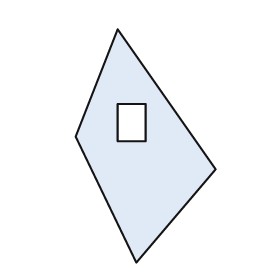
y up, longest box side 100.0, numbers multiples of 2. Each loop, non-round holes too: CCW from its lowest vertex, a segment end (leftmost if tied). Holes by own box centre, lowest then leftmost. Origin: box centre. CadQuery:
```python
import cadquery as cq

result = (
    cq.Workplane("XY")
    .moveTo(-4.0, -50.0)
    .lineTo(30.0, -10.0)
    .lineTo(-12.0, 50.0)
    .lineTo(-30.0, 4.0)
    .close()
    .moveTo(-12.0, 2.0)
    .lineTo(0.0, 2.0)
    .lineTo(0.0, 18.0)
    .lineTo(-12.0, 18.0)
    .close()
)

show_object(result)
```